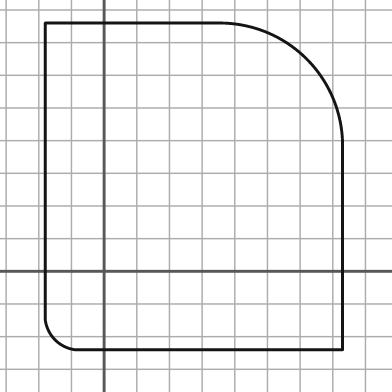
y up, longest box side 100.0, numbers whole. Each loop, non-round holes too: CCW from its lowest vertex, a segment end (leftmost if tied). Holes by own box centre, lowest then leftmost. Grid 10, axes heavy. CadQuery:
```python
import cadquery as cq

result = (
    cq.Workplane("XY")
    .moveTo(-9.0, -24.0)
    .lineTo(73.0, -24.0)
    .lineTo(73.0, 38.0)
    .threePointArc((62.0, 65.0), (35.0, 76.0))
    .lineTo(-18.0, 76.0)
    .lineTo(-18.0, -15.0)
    .threePointArc((-15.0, -21.0), (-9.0, -24.0))
    .close()
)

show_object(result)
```